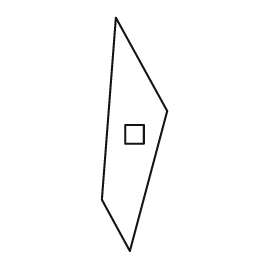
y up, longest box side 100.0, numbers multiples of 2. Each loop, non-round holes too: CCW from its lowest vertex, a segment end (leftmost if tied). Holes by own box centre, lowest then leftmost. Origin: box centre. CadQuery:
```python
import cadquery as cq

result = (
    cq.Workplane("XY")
    .moveTo(-2.0, -50.0)
    .lineTo(14.0, 10.0)
    .lineTo(-8.0, 50.0)
    .lineTo(-14.0, -28.0)
    .close()
    .moveTo(-4.0, -4.0)
    .lineTo(4.0, -4.0)
    .lineTo(4.0, 4.0)
    .lineTo(-4.0, 4.0)
    .close()
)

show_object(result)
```